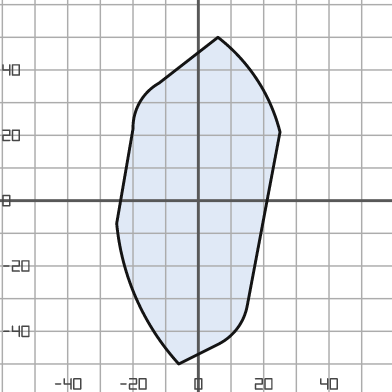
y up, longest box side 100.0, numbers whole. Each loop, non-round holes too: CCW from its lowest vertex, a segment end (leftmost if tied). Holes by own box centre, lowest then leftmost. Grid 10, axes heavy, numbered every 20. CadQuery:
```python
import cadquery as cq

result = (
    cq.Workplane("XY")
    .moveTo(-6.0, -50.0)
    .lineTo(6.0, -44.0)
    .threePointArc((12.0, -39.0), (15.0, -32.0))
    .lineTo(25.0, 21.0)
    .threePointArc((18.0, 37.0), (6.0, 50.0))
    .lineTo(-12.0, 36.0)
    .threePointArc((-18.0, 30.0), (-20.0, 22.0))
    .lineTo(-25.0, -7.0)
    .threePointArc((-19.0, -30.0), (-6.0, -50.0))
    .close()
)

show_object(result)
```